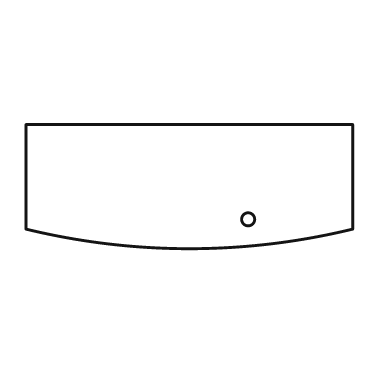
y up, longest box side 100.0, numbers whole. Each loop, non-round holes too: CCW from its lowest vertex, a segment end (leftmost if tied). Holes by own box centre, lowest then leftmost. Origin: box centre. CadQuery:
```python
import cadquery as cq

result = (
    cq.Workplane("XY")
    .moveTo(-50.0, -13.0)
    .threePointArc((0.0, -19.0), (50.0, -13.0))
    .lineTo(50.0, 19.0)
    .lineTo(-50.0, 19.0)
    .close()
    .moveTo(18.0, -10.0)
    .circle(2.0)
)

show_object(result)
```